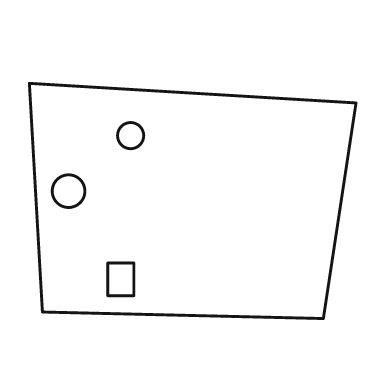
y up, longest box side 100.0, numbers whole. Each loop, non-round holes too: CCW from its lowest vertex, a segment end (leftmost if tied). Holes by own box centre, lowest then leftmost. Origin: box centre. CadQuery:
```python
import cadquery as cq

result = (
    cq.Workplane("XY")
    .moveTo(40.0, -36.0)
    .lineTo(50.0, 30.0)
    .lineTo(-50.0, 36.0)
    .lineTo(-46.0, -34.0)
    .close()
    .moveTo(-26.0, -29.0)
    .lineTo(-18.0, -29.0)
    .lineTo(-18.0, -19.0)
    .lineTo(-26.0, -19.0)
    .close()
    .moveTo(-38.0, 3.0)
    .circle(5.0)
    .moveTo(-19.0, 20.0)
    .circle(4.0)
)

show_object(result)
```